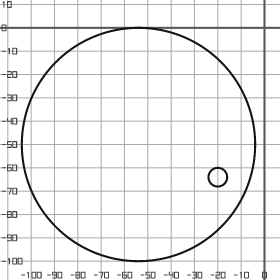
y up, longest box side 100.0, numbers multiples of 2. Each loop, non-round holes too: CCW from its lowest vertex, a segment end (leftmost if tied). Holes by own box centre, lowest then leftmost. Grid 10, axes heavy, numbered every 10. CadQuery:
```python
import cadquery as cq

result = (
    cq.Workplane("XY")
    .moveTo(-54.0, -50.0)
    .circle(50.0)
    .moveTo(-20.0, -64.0)
    .circle(4.0)
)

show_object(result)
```